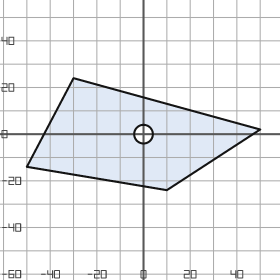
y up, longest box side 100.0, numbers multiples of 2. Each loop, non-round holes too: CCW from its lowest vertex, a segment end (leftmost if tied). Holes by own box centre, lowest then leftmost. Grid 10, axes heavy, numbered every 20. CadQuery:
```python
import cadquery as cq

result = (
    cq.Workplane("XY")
    .moveTo(10.0, -24.0)
    .lineTo(50.0, 2.0)
    .lineTo(-30.0, 24.0)
    .lineTo(-50.0, -14.0)
    .close()
    .moveTo(0.0, 0.0)
    .circle(4.0)
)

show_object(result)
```